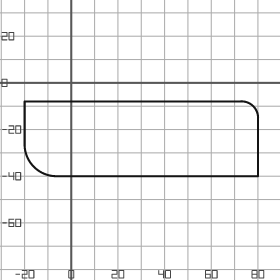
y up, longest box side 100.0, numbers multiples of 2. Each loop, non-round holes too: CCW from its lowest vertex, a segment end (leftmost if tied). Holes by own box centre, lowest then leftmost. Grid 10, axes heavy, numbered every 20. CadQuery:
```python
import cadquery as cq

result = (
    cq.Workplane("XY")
    .moveTo(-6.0, -40.0)
    .lineTo(80.0, -40.0)
    .lineTo(80.0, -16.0)
    .threePointArc((78.0, -10.0), (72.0, -8.0))
    .lineTo(-20.0, -8.0)
    .lineTo(-20.0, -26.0)
    .threePointArc((-16.0, -36.0), (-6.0, -40.0))
    .close()
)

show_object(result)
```